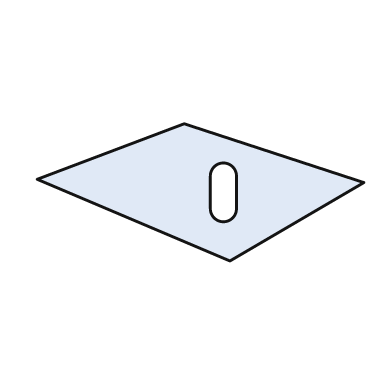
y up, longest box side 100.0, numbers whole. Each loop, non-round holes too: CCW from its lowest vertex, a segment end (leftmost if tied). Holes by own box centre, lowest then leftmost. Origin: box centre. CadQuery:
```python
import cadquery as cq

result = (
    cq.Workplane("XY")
    .moveTo(9.0, -21.0)
    .lineTo(50.0, 3.0)
    .lineTo(-5.0, 21.0)
    .lineTo(-50.0, 4.0)
    .close()
    .moveTo(3.0, -5.0)
    .threePointArc((7.0, -9.0), (11.0, -5.0))
    .lineTo(11.0, 5.0)
    .threePointArc((7.0, 9.0), (3.0, 5.0))
    .close()
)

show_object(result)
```